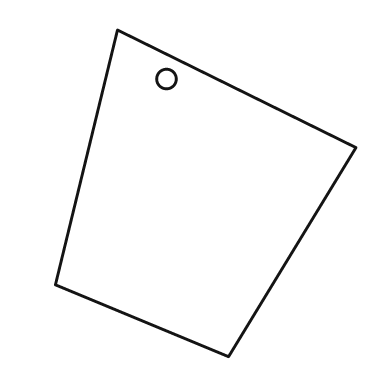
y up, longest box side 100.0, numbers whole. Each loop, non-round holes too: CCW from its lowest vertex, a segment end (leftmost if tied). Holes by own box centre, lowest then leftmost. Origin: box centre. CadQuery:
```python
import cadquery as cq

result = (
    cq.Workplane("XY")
    .moveTo(7.0, -50.0)
    .lineTo(46.0, 14.0)
    .lineTo(-27.0, 50.0)
    .lineTo(-46.0, -28.0)
    .close()
    .moveTo(-12.0, 35.0)
    .circle(3.0)
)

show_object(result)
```